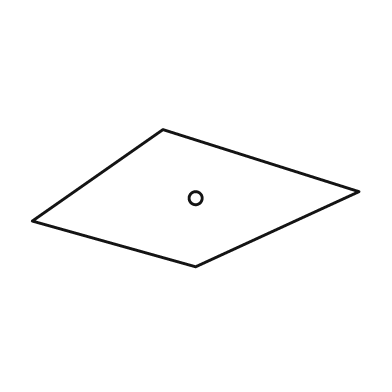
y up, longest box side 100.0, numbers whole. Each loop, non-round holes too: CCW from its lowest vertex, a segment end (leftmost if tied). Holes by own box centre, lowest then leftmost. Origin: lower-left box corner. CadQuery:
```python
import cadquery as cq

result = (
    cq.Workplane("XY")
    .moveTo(50.0, 0.0)
    .lineTo(100.0, 23.0)
    .lineTo(40.0, 42.0)
    .lineTo(0.0, 14.0)
    .close()
    .moveTo(50.0, 21.0)
    .circle(2.0)
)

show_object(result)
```